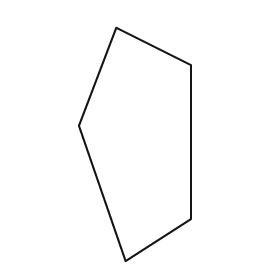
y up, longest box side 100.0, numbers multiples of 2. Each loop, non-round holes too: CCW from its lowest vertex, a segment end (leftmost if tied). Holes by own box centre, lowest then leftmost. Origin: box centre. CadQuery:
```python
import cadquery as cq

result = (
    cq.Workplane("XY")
    .moveTo(-4.0, -50.0)
    .lineTo(24.0, -32.0)
    .lineTo(24.0, 34.0)
    .lineTo(-8.0, 50.0)
    .lineTo(-24.0, 8.0)
    .close()
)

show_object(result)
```